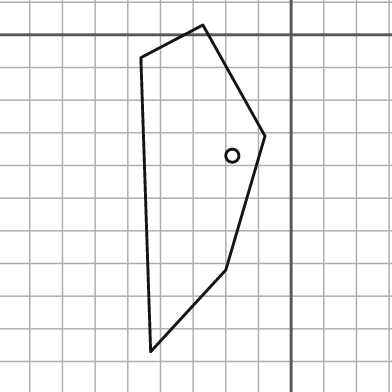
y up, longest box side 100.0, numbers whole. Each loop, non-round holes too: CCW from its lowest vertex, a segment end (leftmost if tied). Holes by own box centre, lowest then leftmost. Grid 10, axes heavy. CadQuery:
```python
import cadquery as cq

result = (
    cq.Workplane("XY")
    .moveTo(-43.0, -97.0)
    .lineTo(-20.0, -72.0)
    .lineTo(-8.0, -31.0)
    .lineTo(-27.0, 3.0)
    .lineTo(-46.0, -7.0)
    .close()
    .moveTo(-18.0, -37.0)
    .circle(2.0)
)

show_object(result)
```